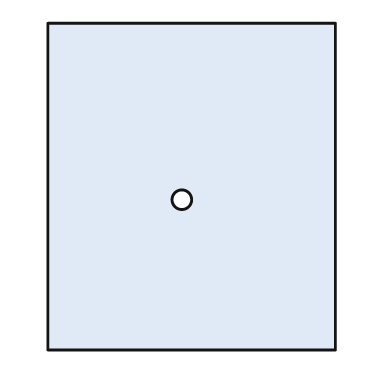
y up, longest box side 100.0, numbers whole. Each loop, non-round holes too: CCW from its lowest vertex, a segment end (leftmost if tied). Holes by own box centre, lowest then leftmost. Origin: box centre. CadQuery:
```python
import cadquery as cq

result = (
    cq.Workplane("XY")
    .moveTo(-44.0, -50.0)
    .lineTo(44.0, -50.0)
    .lineTo(44.0, 50.0)
    .lineTo(-44.0, 50.0)
    .close()
    .moveTo(-3.0, -4.0)
    .circle(3.0)
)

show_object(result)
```